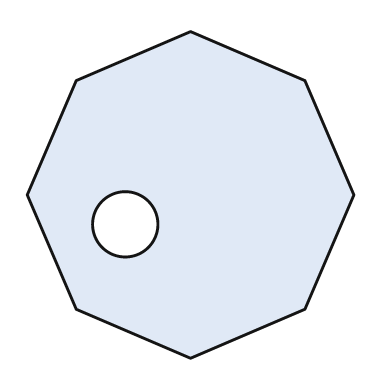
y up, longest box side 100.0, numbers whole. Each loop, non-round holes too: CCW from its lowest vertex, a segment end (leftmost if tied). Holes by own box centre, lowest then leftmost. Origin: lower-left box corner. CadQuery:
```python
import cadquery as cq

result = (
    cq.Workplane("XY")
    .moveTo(50.0, 0.0)
    .lineTo(85.0, 15.0)
    .lineTo(100.0, 50.0)
    .lineTo(85.0, 85.0)
    .lineTo(50.0, 100.0)
    .lineTo(15.0, 85.0)
    .lineTo(0.0, 50.0)
    .lineTo(15.0, 15.0)
    .close()
    .moveTo(30.0, 41.0)
    .circle(10.0)
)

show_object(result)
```